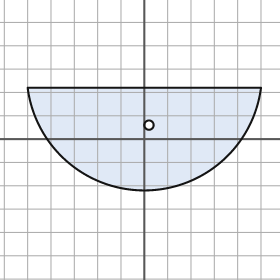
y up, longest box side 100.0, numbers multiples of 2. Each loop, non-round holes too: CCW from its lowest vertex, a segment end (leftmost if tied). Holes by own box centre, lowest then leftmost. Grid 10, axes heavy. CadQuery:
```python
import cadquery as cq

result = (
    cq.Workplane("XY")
    .moveTo(-50.0, 22.0)
    .threePointArc((0.0, -22.0), (50.0, 22.0))
    .close()
    .moveTo(2.0, 6.0)
    .circle(2.0)
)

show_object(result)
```